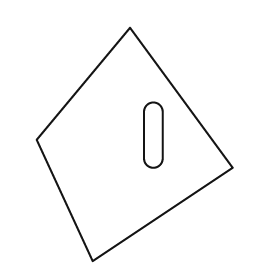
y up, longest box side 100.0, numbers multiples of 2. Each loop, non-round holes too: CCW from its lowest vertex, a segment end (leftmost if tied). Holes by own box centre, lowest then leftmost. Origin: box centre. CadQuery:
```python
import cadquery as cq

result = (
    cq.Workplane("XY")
    .moveTo(-18.0, -50.0)
    .lineTo(42.0, -10.0)
    .lineTo(-2.0, 50.0)
    .lineTo(-42.0, 2.0)
    .close()
    .moveTo(4.0, -6.0)
    .threePointArc((8.0, -10.0), (12.0, -6.0))
    .lineTo(12.0, 14.0)
    .threePointArc((8.0, 18.0), (4.0, 14.0))
    .close()
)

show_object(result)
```